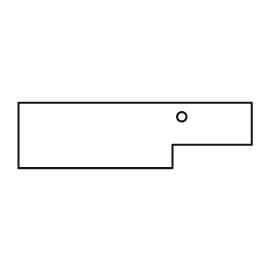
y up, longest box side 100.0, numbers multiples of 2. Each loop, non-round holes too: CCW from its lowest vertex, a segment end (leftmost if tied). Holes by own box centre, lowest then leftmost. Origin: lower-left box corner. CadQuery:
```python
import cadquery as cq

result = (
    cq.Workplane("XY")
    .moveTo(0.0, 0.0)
    .lineTo(66.0, 0.0)
    .lineTo(66.0, 10.0)
    .lineTo(100.0, 10.0)
    .lineTo(100.0, 28.0)
    .lineTo(0.0, 28.0)
    .close()
    .moveTo(70.0, 22.0)
    .circle(2.0)
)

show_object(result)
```